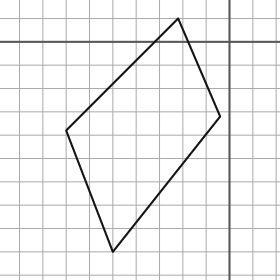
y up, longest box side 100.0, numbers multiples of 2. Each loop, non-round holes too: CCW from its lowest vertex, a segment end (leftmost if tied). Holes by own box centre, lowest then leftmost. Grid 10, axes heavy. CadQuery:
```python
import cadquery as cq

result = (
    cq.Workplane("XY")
    .moveTo(-50.0, -90.0)
    .lineTo(-4.0, -32.0)
    .lineTo(-22.0, 10.0)
    .lineTo(-70.0, -38.0)
    .close()
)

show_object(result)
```